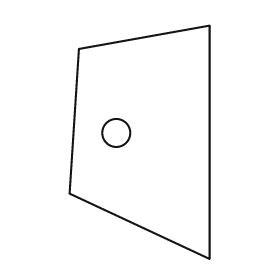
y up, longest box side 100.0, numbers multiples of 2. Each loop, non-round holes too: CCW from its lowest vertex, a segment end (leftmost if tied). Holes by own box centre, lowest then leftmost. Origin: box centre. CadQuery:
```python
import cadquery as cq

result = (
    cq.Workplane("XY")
    .moveTo(30.0, -50.0)
    .lineTo(30.0, 50.0)
    .lineTo(-26.0, 40.0)
    .lineTo(-30.0, -22.0)
    .close()
    .moveTo(-10.0, 4.0)
    .circle(6.0)
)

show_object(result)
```